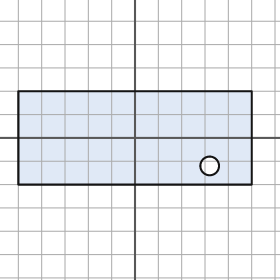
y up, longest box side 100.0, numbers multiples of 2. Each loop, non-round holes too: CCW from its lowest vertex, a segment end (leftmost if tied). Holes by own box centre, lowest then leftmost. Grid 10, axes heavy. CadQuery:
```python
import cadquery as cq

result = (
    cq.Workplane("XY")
    .moveTo(-50.0, -20.0)
    .lineTo(50.0, -20.0)
    .lineTo(50.0, 20.0)
    .lineTo(-50.0, 20.0)
    .close()
    .moveTo(32.0, -12.0)
    .circle(4.0)
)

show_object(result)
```